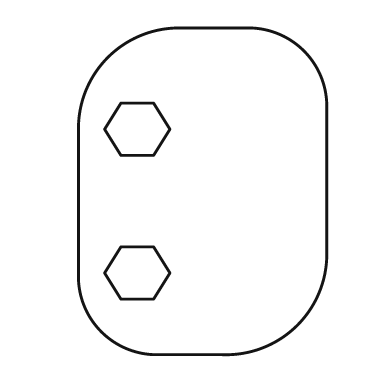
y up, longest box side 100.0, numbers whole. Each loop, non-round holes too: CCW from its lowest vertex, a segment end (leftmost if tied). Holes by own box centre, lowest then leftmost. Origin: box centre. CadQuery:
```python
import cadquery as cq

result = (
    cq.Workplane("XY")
    .moveTo(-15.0, -50.0)
    .lineTo(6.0, -50.0)
    .threePointArc((29.0, -41.0), (38.0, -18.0))
    .lineTo(38.0, 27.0)
    .threePointArc((31.0, 43.0), (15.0, 50.0))
    .lineTo(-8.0, 50.0)
    .threePointArc((-29.0, 41.0), (-38.0, 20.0))
    .lineTo(-38.0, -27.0)
    .threePointArc((-31.0, -43.0), (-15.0, -50.0))
    .close()
    .moveTo(-25.0, -33.0)
    .lineTo(-15.0, -33.0)
    .lineTo(-10.0, -25.0)
    .lineTo(-15.0, -17.0)
    .lineTo(-25.0, -17.0)
    .lineTo(-30.0, -25.0)
    .close()
    .moveTo(-25.0, 11.0)
    .lineTo(-15.0, 11.0)
    .lineTo(-10.0, 19.0)
    .lineTo(-15.0, 27.0)
    .lineTo(-25.0, 27.0)
    .lineTo(-30.0, 19.0)
    .close()
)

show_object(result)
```